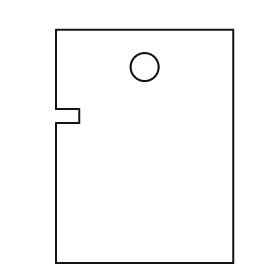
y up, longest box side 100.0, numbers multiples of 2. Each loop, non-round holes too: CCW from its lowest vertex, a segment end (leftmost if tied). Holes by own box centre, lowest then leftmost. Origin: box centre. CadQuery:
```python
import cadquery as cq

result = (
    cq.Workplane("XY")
    .moveTo(-38.0, -50.0)
    .lineTo(38.0, -50.0)
    .lineTo(38.0, 50.0)
    .lineTo(-38.0, 50.0)
    .lineTo(-38.0, 16.0)
    .lineTo(-28.0, 16.0)
    .lineTo(-28.0, 10.0)
    .lineTo(-38.0, 10.0)
    .close()
    .moveTo(0.0, 34.0)
    .circle(6.0)
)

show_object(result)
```